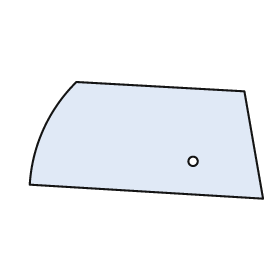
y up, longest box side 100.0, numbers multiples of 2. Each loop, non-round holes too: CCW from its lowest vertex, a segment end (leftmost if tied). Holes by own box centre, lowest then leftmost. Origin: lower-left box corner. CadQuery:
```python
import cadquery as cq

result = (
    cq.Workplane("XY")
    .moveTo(100.0, 0.0)
    .lineTo(92.0, 46.0)
    .lineTo(20.0, 50.0)
    .threePointArc((6.0, 30.0), (0.0, 6.0))
    .close()
    .moveTo(70.0, 16.0)
    .circle(2.0)
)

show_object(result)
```